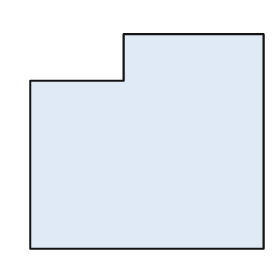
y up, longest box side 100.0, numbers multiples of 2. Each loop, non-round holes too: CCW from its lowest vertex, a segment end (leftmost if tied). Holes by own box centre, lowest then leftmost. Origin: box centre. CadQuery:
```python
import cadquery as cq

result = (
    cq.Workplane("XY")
    .moveTo(-50.0, -46.0)
    .lineTo(50.0, -46.0)
    .lineTo(50.0, 46.0)
    .lineTo(-10.0, 46.0)
    .lineTo(-10.0, 26.0)
    .lineTo(-50.0, 26.0)
    .close()
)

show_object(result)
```